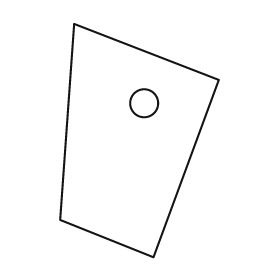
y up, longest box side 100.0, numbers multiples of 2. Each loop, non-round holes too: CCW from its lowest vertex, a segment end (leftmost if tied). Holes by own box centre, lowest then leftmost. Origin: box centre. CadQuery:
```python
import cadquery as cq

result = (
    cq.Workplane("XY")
    .moveTo(6.0, -50.0)
    .lineTo(34.0, 26.0)
    .lineTo(-28.0, 50.0)
    .lineTo(-34.0, -34.0)
    .close()
    .moveTo(2.0, 16.0)
    .circle(6.0)
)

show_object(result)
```